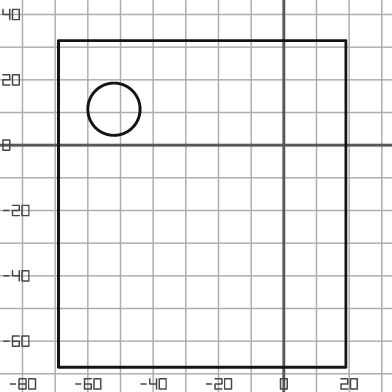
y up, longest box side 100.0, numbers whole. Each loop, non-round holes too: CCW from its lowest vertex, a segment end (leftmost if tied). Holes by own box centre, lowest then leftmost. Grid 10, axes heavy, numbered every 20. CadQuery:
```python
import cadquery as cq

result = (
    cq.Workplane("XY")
    .moveTo(-69.0, -68.0)
    .lineTo(19.0, -68.0)
    .lineTo(19.0, 32.0)
    .lineTo(-69.0, 32.0)
    .close()
    .moveTo(-52.0, 11.0)
    .circle(8.0)
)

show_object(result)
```